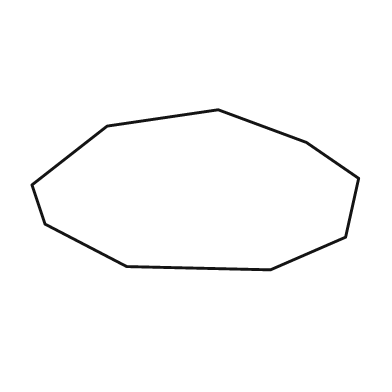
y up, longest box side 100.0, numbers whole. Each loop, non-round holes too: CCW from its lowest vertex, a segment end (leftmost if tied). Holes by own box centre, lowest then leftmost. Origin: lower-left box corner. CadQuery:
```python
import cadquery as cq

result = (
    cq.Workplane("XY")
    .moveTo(73.0, 0.0)
    .lineTo(96.0, 10.0)
    .lineTo(100.0, 28.0)
    .lineTo(84.0, 39.0)
    .lineTo(57.0, 49.0)
    .lineTo(23.0, 44.0)
    .lineTo(0.0, 26.0)
    .lineTo(4.0, 14.0)
    .lineTo(29.0, 1.0)
    .close()
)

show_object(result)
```